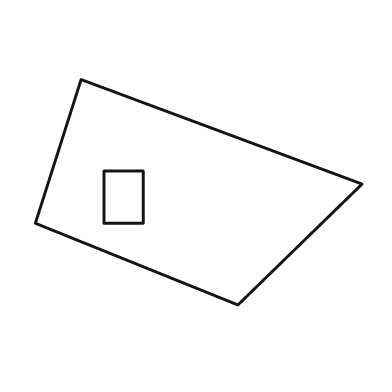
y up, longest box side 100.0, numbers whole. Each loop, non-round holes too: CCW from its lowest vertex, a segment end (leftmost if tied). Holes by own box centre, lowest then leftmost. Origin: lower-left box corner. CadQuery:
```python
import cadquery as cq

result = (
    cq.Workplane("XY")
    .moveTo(62.0, 0.0)
    .lineTo(100.0, 37.0)
    .lineTo(14.0, 69.0)
    .lineTo(0.0, 25.0)
    .close()
    .moveTo(21.0, 25.0)
    .lineTo(33.0, 25.0)
    .lineTo(33.0, 41.0)
    .lineTo(21.0, 41.0)
    .close()
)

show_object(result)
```